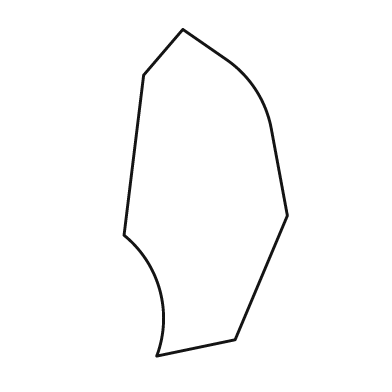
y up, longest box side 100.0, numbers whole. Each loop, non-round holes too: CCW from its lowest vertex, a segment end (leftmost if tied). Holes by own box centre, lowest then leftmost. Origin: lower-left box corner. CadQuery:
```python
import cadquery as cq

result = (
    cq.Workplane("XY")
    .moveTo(10.0, 0.0)
    .lineTo(34.0, 5.0)
    .lineTo(50.0, 43.0)
    .lineTo(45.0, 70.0)
    .threePointArc((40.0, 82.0), (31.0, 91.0))
    .lineTo(18.0, 100.0)
    .lineTo(6.0, 86.0)
    .lineTo(0.0, 37.0)
    .threePointArc((11.0, 20.0), (10.0, 0.0))
    .close()
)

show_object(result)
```